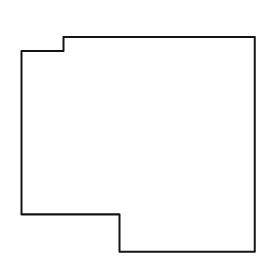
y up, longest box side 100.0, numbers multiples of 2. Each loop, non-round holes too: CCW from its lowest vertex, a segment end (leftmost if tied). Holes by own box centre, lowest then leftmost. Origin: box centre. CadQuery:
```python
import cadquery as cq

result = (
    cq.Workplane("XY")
    .moveTo(-8.0, -46.0)
    .lineTo(50.0, -46.0)
    .lineTo(50.0, 46.0)
    .lineTo(-32.0, 46.0)
    .lineTo(-32.0, 40.0)
    .lineTo(-50.0, 40.0)
    .lineTo(-50.0, -30.0)
    .lineTo(-8.0, -30.0)
    .close()
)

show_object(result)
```